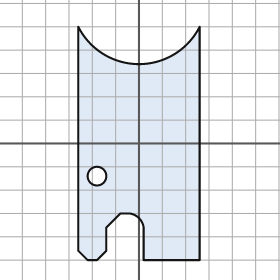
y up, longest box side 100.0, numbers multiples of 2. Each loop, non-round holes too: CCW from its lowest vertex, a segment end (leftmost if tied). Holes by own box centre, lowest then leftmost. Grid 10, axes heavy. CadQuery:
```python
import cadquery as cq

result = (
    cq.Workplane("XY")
    .moveTo(-22.0, -50.0)
    .lineTo(-18.0, -50.0)
    .lineTo(-14.0, -46.0)
    .lineTo(-14.0, -36.0)
    .lineTo(-8.0, -30.0)
    .lineTo(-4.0, -30.0)
    .threePointArc((0.0, -32.0), (2.0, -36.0))
    .lineTo(2.0, -50.0)
    .lineTo(26.0, -50.0)
    .lineTo(26.0, 50.0)
    .threePointArc((0.0, 34.0), (-26.0, 50.0))
    .lineTo(-26.0, -46.0)
    .close()
    .moveTo(-18.0, -14.0)
    .circle(4.0)
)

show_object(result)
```